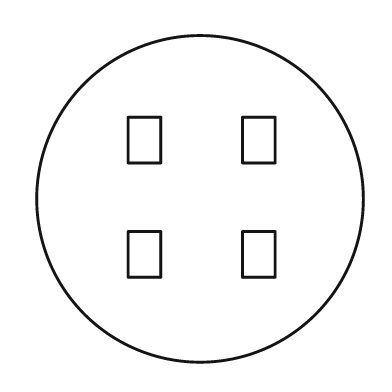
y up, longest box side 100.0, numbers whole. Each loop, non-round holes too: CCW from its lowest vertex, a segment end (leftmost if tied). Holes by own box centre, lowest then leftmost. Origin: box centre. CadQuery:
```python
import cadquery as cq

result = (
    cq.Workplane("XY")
    .moveTo(0.0, 0.0)
    .circle(50.0)
    .moveTo(-22.0, -24.0)
    .lineTo(-12.0, -24.0)
    .lineTo(-12.0, -10.0)
    .lineTo(-22.0, -10.0)
    .close()
    .moveTo(13.0, -24.0)
    .lineTo(23.0, -24.0)
    .lineTo(23.0, -10.0)
    .lineTo(13.0, -10.0)
    .close()
    .moveTo(-22.0, 11.0)
    .lineTo(-12.0, 11.0)
    .lineTo(-12.0, 25.0)
    .lineTo(-22.0, 25.0)
    .close()
    .moveTo(13.0, 11.0)
    .lineTo(23.0, 11.0)
    .lineTo(23.0, 25.0)
    .lineTo(13.0, 25.0)
    .close()
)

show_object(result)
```